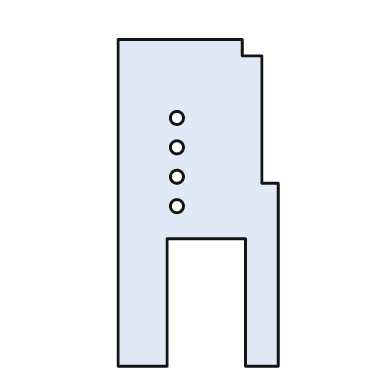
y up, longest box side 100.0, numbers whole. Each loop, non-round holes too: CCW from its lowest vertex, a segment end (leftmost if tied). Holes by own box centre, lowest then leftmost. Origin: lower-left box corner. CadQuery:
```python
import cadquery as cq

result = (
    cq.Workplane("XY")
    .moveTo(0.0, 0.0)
    .lineTo(15.0, 0.0)
    .lineTo(15.0, 39.0)
    .lineTo(39.0, 39.0)
    .lineTo(39.0, 0.0)
    .lineTo(49.0, 0.0)
    .lineTo(49.0, 56.0)
    .lineTo(44.0, 56.0)
    .lineTo(44.0, 95.0)
    .lineTo(38.0, 95.0)
    .lineTo(38.0, 100.0)
    .lineTo(0.0, 100.0)
    .close()
    .moveTo(18.0, 49.0)
    .circle(2.0)
    .moveTo(18.0, 58.0)
    .circle(2.0)
    .moveTo(18.0, 67.0)
    .circle(2.0)
    .moveTo(18.0, 76.0)
    .circle(2.0)
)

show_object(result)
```